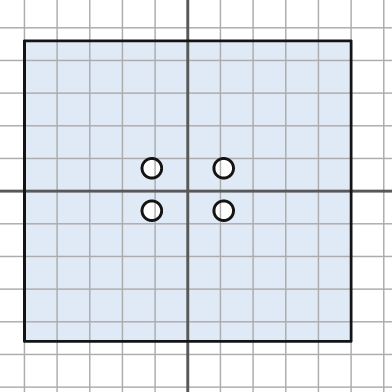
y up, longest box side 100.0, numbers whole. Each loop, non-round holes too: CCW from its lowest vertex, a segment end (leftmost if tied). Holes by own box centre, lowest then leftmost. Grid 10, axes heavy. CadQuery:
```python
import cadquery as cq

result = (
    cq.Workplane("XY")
    .moveTo(-50.0, -46.0)
    .lineTo(50.0, -46.0)
    .lineTo(50.0, 46.0)
    .lineTo(-50.0, 46.0)
    .close()
    .moveTo(-11.0, -6.0)
    .circle(3.0)
    .moveTo(11.0, -6.0)
    .circle(3.0)
    .moveTo(-11.0, 7.0)
    .circle(3.0)
    .moveTo(11.0, 7.0)
    .circle(3.0)
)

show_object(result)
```